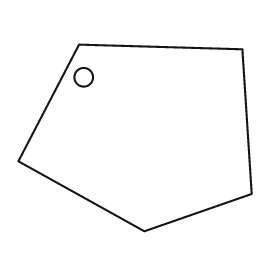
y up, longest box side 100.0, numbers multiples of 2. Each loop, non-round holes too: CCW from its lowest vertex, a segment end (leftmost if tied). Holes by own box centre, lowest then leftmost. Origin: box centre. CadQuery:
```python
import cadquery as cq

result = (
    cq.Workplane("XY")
    .moveTo(4.0, -40.0)
    .lineTo(50.0, -24.0)
    .lineTo(46.0, 38.0)
    .lineTo(-24.0, 40.0)
    .lineTo(-50.0, -10.0)
    .close()
    .moveTo(-22.0, 26.0)
    .circle(4.0)
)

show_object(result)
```